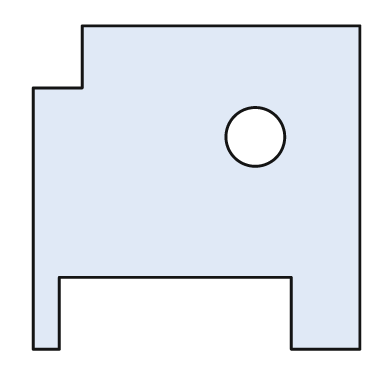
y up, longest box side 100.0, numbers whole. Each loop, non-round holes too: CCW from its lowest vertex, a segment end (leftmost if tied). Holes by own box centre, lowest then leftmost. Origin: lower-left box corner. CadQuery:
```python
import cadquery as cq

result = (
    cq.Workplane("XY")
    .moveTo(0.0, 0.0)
    .lineTo(8.0, 0.0)
    .lineTo(8.0, 22.0)
    .lineTo(79.0, 22.0)
    .lineTo(79.0, 0.0)
    .lineTo(100.0, 0.0)
    .lineTo(100.0, 99.0)
    .lineTo(15.0, 99.0)
    .lineTo(15.0, 80.0)
    .lineTo(0.0, 80.0)
    .close()
    .moveTo(68.0, 65.0)
    .circle(9.0)
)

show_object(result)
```